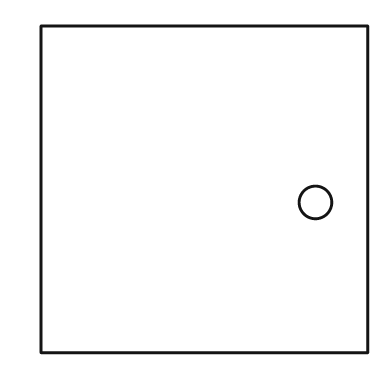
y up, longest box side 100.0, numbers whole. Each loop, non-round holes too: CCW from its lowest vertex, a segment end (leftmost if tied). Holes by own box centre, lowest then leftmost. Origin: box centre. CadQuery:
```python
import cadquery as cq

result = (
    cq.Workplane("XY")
    .moveTo(-50.0, -50.0)
    .lineTo(50.0, -50.0)
    .lineTo(50.0, 50.0)
    .lineTo(-50.0, 50.0)
    .close()
    .moveTo(34.0, -4.0)
    .circle(5.0)
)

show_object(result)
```